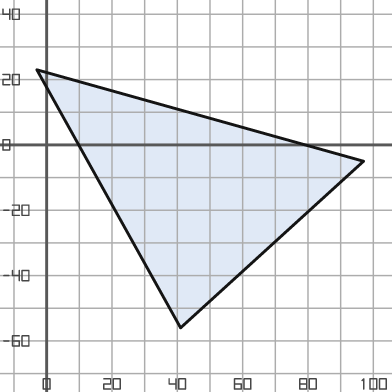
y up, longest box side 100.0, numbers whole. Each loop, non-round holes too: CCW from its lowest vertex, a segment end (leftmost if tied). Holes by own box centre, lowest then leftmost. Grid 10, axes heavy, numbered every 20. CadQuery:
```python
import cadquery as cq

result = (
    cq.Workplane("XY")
    .moveTo(41.0, -56.0)
    .lineTo(97.0, -5.0)
    .lineTo(-3.0, 23.0)
    .close()
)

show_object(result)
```